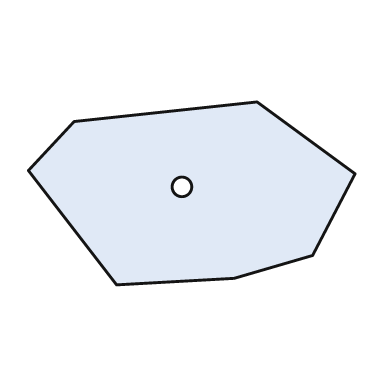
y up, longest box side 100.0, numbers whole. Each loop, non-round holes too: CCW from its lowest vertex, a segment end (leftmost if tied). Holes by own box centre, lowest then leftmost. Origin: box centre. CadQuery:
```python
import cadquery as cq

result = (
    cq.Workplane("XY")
    .moveTo(-23.0, -28.0)
    .lineTo(13.0, -26.0)
    .lineTo(37.0, -19.0)
    .lineTo(50.0, 6.0)
    .lineTo(20.0, 28.0)
    .lineTo(-36.0, 22.0)
    .lineTo(-50.0, 7.0)
    .close()
    .moveTo(-3.0, 2.0)
    .circle(3.0)
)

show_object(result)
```